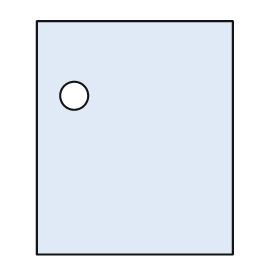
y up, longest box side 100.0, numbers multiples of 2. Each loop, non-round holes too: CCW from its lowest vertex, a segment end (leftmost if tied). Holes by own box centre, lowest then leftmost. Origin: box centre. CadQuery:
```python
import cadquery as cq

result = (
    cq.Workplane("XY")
    .moveTo(-42.0, -50.0)
    .lineTo(42.0, -50.0)
    .lineTo(42.0, 50.0)
    .lineTo(-42.0, 50.0)
    .close()
    .moveTo(-26.0, 18.0)
    .circle(6.0)
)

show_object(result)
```